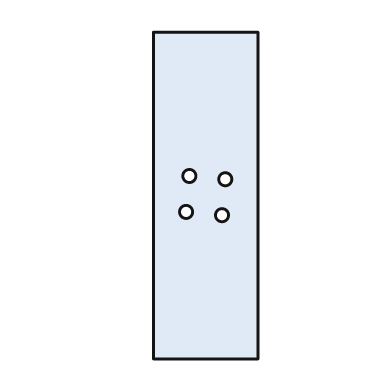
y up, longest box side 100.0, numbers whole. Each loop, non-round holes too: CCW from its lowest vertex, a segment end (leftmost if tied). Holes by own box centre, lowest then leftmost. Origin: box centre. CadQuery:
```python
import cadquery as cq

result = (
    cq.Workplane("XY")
    .moveTo(-16.0, -50.0)
    .lineTo(16.0, -50.0)
    .lineTo(16.0, 50.0)
    .lineTo(-16.0, 50.0)
    .close()
    .moveTo(5.0, -6.0)
    .circle(2.0)
    .moveTo(-6.0, -5.0)
    .circle(2.0)
    .moveTo(6.0, 5.0)
    .circle(2.0)
    .moveTo(-5.0, 6.0)
    .circle(2.0)
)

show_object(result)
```